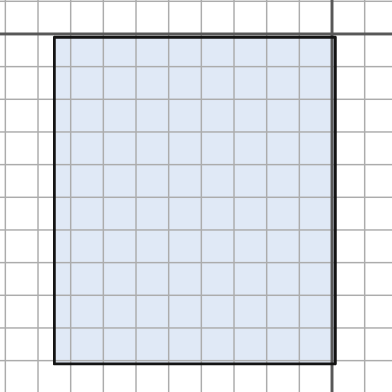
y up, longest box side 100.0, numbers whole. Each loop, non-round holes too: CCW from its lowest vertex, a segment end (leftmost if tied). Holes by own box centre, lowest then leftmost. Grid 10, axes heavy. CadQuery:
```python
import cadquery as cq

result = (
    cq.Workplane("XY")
    .moveTo(-85.0, -101.0)
    .lineTo(1.0, -101.0)
    .lineTo(1.0, -1.0)
    .lineTo(-85.0, -1.0)
    .close()
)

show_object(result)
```